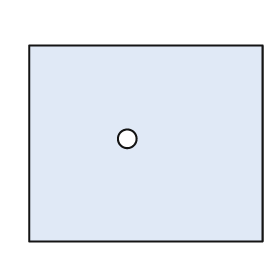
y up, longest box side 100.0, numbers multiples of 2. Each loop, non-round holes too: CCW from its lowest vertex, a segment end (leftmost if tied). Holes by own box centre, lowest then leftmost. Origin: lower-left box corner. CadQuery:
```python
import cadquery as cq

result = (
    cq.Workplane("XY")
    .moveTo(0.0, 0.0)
    .lineTo(100.0, 0.0)
    .lineTo(100.0, 84.0)
    .lineTo(0.0, 84.0)
    .close()
    .moveTo(42.0, 44.0)
    .circle(4.0)
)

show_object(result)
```